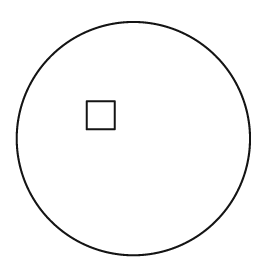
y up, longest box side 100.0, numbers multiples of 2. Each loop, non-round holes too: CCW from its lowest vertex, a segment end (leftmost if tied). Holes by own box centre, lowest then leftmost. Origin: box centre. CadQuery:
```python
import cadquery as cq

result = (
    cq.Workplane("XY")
    .moveTo(0.0, 0.0)
    .circle(50.0)
    .moveTo(-20.0, 4.0)
    .lineTo(-8.0, 4.0)
    .lineTo(-8.0, 16.0)
    .lineTo(-20.0, 16.0)
    .close()
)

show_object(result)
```